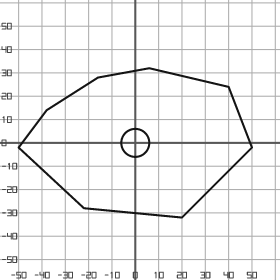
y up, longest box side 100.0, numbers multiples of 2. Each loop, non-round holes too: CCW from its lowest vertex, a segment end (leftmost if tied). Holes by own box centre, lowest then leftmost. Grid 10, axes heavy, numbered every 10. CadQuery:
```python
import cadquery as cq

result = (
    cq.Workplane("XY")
    .moveTo(20.0, -32.0)
    .lineTo(50.0, -2.0)
    .lineTo(40.0, 24.0)
    .lineTo(6.0, 32.0)
    .lineTo(-16.0, 28.0)
    .lineTo(-38.0, 14.0)
    .lineTo(-50.0, -2.0)
    .lineTo(-22.0, -28.0)
    .close()
    .moveTo(0.0, 0.0)
    .circle(6.0)
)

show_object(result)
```